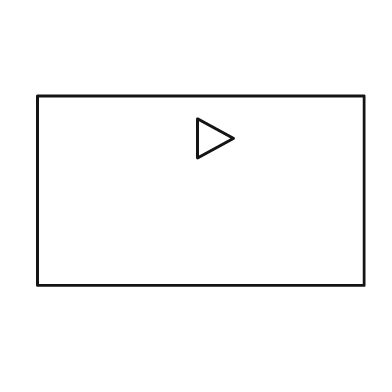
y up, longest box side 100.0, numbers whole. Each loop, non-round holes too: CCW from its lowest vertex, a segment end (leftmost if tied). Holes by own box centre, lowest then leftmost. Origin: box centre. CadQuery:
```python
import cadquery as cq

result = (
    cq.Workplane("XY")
    .moveTo(-50.0, -29.0)
    .lineTo(50.0, -29.0)
    .lineTo(50.0, 29.0)
    .lineTo(-50.0, 29.0)
    .close()
    .moveTo(-1.0, 10.0)
    .lineTo(10.0, 16.0)
    .lineTo(-1.0, 22.0)
    .close()
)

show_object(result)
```